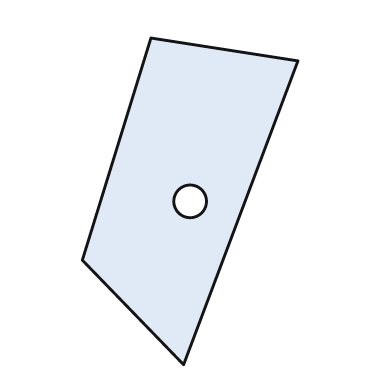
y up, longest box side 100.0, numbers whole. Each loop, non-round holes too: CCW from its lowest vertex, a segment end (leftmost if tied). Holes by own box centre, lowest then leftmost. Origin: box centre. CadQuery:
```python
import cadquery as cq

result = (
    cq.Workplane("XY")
    .moveTo(-2.0, -50.0)
    .lineTo(33.0, 43.0)
    .lineTo(-12.0, 50.0)
    .lineTo(-33.0, -18.0)
    .close()
    .moveTo(0.0, 0.0)
    .circle(5.0)
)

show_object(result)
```